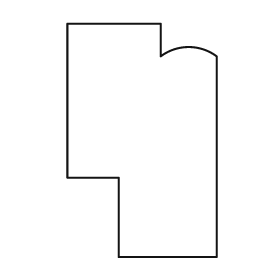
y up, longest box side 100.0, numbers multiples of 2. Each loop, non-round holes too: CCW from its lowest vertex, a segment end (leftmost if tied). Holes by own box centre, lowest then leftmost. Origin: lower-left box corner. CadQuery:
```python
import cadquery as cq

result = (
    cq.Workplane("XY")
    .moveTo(22.0, 0.0)
    .lineTo(64.0, 0.0)
    .lineTo(64.0, 86.0)
    .threePointArc((52.0, 90.0), (40.0, 86.0))
    .lineTo(40.0, 100.0)
    .lineTo(0.0, 100.0)
    .lineTo(0.0, 34.0)
    .lineTo(22.0, 34.0)
    .close()
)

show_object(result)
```